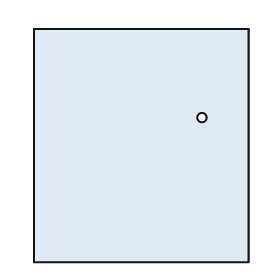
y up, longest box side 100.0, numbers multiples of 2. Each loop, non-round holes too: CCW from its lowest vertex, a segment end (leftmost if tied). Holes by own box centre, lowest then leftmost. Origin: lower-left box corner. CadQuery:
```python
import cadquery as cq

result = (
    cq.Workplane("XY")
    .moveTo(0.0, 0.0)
    .lineTo(92.0, 0.0)
    .lineTo(92.0, 100.0)
    .lineTo(0.0, 100.0)
    .close()
    .moveTo(72.0, 62.0)
    .circle(2.0)
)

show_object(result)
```